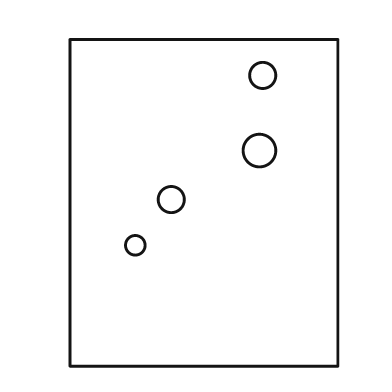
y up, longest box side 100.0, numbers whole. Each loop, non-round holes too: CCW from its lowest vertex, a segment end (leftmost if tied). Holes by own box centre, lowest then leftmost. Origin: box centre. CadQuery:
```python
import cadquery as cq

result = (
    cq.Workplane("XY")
    .moveTo(-41.0, -50.0)
    .lineTo(41.0, -50.0)
    .lineTo(41.0, 50.0)
    .lineTo(-41.0, 50.0)
    .close()
    .moveTo(-21.0, -13.0)
    .circle(3.0)
    .moveTo(-10.0, 1.0)
    .circle(4.0)
    .moveTo(17.0, 16.0)
    .circle(5.0)
    .moveTo(18.0, 39.0)
    .circle(4.0)
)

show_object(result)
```